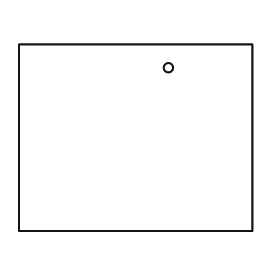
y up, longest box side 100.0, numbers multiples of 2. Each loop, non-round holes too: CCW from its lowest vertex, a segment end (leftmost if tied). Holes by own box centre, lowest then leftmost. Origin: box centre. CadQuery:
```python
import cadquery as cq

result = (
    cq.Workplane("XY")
    .moveTo(-50.0, -40.0)
    .lineTo(50.0, -40.0)
    .lineTo(50.0, 40.0)
    .lineTo(-50.0, 40.0)
    .close()
    .moveTo(14.0, 30.0)
    .circle(2.0)
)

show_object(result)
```